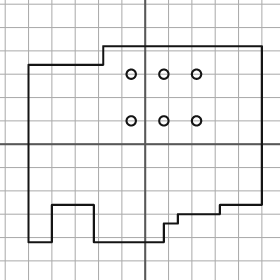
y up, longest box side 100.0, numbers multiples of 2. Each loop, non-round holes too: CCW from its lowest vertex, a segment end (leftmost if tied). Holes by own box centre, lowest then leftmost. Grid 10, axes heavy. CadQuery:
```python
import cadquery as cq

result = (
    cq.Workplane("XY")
    .moveTo(-50.0, -42.0)
    .lineTo(-40.0, -42.0)
    .lineTo(-40.0, -26.0)
    .lineTo(-22.0, -26.0)
    .lineTo(-22.0, -42.0)
    .lineTo(8.0, -42.0)
    .lineTo(8.0, -34.0)
    .lineTo(14.0, -34.0)
    .lineTo(14.0, -30.0)
    .lineTo(32.0, -30.0)
    .lineTo(32.0, -26.0)
    .lineTo(50.0, -26.0)
    .lineTo(50.0, 42.0)
    .lineTo(-18.0, 42.0)
    .lineTo(-18.0, 34.0)
    .lineTo(-50.0, 34.0)
    .close()
    .moveTo(-6.0, 10.0)
    .circle(2.0)
    .moveTo(8.0, 10.0)
    .circle(2.0)
    .moveTo(22.0, 10.0)
    .circle(2.0)
    .moveTo(-6.0, 30.0)
    .circle(2.0)
    .moveTo(8.0, 30.0)
    .circle(2.0)
    .moveTo(22.0, 30.0)
    .circle(2.0)
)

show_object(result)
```